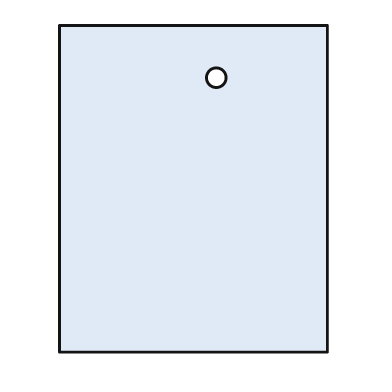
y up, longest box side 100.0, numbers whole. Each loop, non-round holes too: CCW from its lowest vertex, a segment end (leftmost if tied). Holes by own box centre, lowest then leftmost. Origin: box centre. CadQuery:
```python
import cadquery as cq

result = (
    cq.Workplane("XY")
    .moveTo(-41.0, -50.0)
    .lineTo(41.0, -50.0)
    .lineTo(41.0, 50.0)
    .lineTo(-41.0, 50.0)
    .close()
    .moveTo(7.0, 34.0)
    .circle(3.0)
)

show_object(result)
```